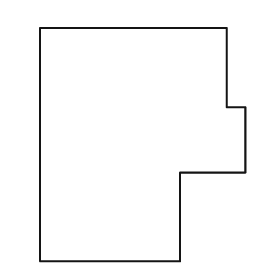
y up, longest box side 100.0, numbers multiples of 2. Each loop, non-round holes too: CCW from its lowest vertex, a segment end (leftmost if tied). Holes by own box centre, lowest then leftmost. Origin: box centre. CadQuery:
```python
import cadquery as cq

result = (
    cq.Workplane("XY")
    .moveTo(-44.0, -50.0)
    .lineTo(16.0, -50.0)
    .lineTo(16.0, -12.0)
    .lineTo(44.0, -12.0)
    .lineTo(44.0, 16.0)
    .lineTo(36.0, 16.0)
    .lineTo(36.0, 50.0)
    .lineTo(-44.0, 50.0)
    .close()
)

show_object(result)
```